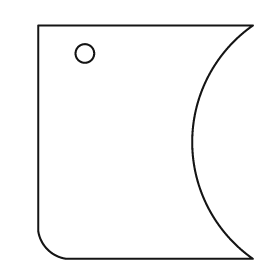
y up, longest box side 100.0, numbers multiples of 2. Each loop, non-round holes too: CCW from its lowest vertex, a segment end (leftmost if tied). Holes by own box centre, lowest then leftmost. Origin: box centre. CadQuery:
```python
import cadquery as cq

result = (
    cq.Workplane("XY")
    .moveTo(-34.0, -50.0)
    .lineTo(46.0, -50.0)
    .threePointArc((20.0, 0.0), (46.0, 50.0))
    .lineTo(-46.0, 50.0)
    .lineTo(-46.0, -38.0)
    .threePointArc((-42.0, -46.0), (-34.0, -50.0))
    .close()
    .moveTo(-26.0, 38.0)
    .circle(4.0)
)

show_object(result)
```